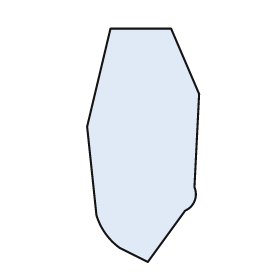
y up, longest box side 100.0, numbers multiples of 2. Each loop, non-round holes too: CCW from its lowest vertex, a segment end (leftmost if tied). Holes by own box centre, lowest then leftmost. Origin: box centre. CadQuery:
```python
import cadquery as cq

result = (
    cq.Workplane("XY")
    .moveTo(2.0, -50.0)
    .lineTo(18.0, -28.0)
    .threePointArc((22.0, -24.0), (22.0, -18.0))
    .lineTo(24.0, 22.0)
    .lineTo(12.0, 50.0)
    .lineTo(-14.0, 50.0)
    .lineTo(-24.0, 8.0)
    .lineTo(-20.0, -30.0)
    .threePointArc((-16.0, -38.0), (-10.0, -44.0))
    .close()
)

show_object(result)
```